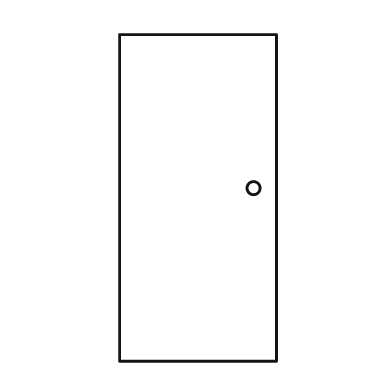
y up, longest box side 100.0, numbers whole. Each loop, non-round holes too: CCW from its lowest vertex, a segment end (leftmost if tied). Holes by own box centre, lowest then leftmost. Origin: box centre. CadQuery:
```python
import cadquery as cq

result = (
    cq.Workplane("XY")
    .moveTo(-24.0, -50.0)
    .lineTo(24.0, -50.0)
    .lineTo(24.0, 50.0)
    .lineTo(-24.0, 50.0)
    .close()
    .moveTo(17.0, 3.0)
    .circle(2.0)
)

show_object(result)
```